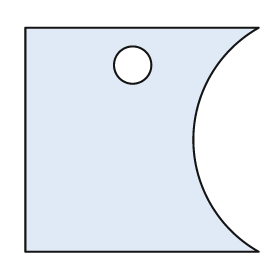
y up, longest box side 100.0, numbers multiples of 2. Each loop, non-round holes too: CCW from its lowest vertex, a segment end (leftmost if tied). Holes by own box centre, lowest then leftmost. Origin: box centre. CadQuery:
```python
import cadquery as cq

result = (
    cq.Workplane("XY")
    .moveTo(-50.0, -48.0)
    .lineTo(50.0, -48.0)
    .threePointArc((22.0, 0.0), (50.0, 48.0))
    .lineTo(-50.0, 48.0)
    .close()
    .moveTo(-4.0, 32.0)
    .circle(8.0)
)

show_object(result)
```